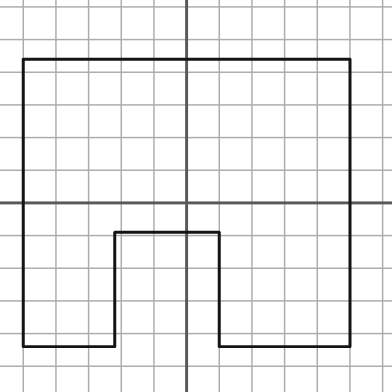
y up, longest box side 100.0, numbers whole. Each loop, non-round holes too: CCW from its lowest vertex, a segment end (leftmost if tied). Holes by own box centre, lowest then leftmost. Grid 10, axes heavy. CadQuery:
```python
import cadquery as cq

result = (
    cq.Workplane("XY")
    .moveTo(-50.0, -44.0)
    .lineTo(-22.0, -44.0)
    .lineTo(-22.0, -9.0)
    .lineTo(10.0, -9.0)
    .lineTo(10.0, -44.0)
    .lineTo(50.0, -44.0)
    .lineTo(50.0, 44.0)
    .lineTo(-50.0, 44.0)
    .close()
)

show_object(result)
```